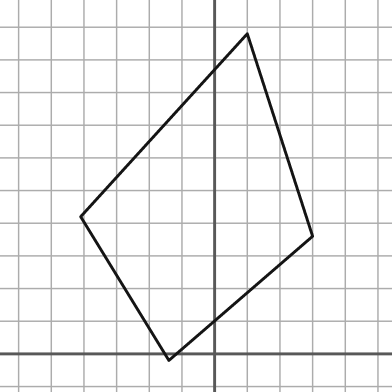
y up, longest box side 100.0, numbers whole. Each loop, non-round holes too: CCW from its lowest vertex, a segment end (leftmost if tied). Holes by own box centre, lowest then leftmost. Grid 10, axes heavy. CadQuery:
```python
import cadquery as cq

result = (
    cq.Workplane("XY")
    .moveTo(-14.0, -2.0)
    .lineTo(30.0, 36.0)
    .lineTo(10.0, 98.0)
    .lineTo(-41.0, 42.0)
    .close()
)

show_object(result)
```